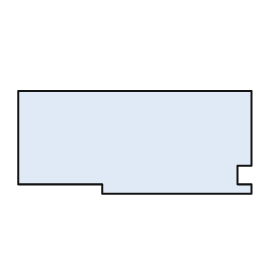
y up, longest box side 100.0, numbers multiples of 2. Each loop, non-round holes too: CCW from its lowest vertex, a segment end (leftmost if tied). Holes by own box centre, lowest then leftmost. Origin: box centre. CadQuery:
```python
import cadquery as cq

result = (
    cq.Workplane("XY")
    .moveTo(-14.0, -22.0)
    .lineTo(50.0, -22.0)
    .lineTo(50.0, -18.0)
    .lineTo(44.0, -18.0)
    .lineTo(44.0, -10.0)
    .lineTo(50.0, -10.0)
    .lineTo(50.0, 22.0)
    .lineTo(-50.0, 22.0)
    .lineTo(-50.0, -18.0)
    .lineTo(-14.0, -18.0)
    .close()
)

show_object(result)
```